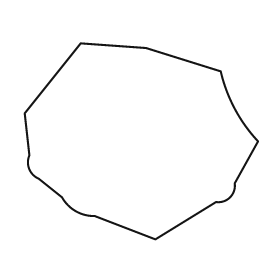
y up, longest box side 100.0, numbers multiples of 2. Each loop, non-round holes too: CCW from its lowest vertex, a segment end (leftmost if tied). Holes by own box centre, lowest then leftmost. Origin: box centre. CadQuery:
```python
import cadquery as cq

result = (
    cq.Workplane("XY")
    .moveTo(6.0, -42.0)
    .lineTo(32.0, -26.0)
    .threePointArc((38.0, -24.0), (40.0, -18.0))
    .lineTo(50.0, 0.0)
    .threePointArc((40.0, 14.0), (34.0, 30.0))
    .lineTo(2.0, 40.0)
    .lineTo(-26.0, 42.0)
    .lineTo(-50.0, 12.0)
    .lineTo(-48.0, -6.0)
    .threePointArc((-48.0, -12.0), (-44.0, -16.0))
    .lineTo(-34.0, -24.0)
    .threePointArc((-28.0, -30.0), (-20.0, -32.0))
    .close()
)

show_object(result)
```